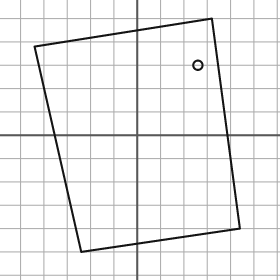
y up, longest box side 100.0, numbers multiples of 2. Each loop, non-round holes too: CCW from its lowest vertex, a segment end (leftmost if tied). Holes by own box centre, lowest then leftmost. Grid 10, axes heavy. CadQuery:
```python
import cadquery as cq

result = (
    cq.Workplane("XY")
    .moveTo(-24.0, -50.0)
    .lineTo(44.0, -40.0)
    .lineTo(32.0, 50.0)
    .lineTo(-44.0, 38.0)
    .close()
    .moveTo(26.0, 30.0)
    .circle(2.0)
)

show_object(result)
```